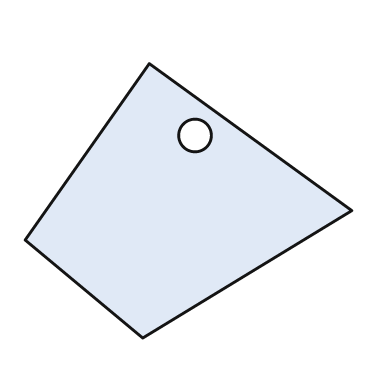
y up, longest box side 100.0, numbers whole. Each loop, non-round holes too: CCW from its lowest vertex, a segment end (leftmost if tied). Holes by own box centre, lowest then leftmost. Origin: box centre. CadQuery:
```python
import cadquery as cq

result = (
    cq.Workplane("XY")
    .moveTo(-14.0, -42.0)
    .lineTo(50.0, -3.0)
    .lineTo(-12.0, 42.0)
    .lineTo(-50.0, -12.0)
    .close()
    .moveTo(2.0, 20.0)
    .circle(5.0)
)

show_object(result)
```